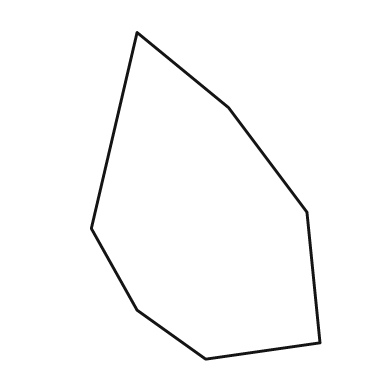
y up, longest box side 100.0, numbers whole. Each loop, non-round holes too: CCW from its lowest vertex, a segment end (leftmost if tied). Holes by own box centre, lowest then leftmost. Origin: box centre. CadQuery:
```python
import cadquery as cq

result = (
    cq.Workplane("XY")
    .moveTo(0.0, -50.0)
    .lineTo(35.0, -45.0)
    .lineTo(31.0, -5.0)
    .lineTo(7.0, 27.0)
    .lineTo(-21.0, 50.0)
    .lineTo(-35.0, -10.0)
    .lineTo(-21.0, -35.0)
    .close()
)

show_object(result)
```